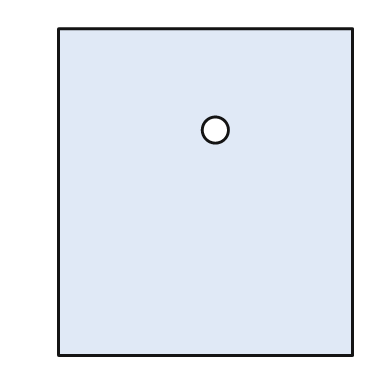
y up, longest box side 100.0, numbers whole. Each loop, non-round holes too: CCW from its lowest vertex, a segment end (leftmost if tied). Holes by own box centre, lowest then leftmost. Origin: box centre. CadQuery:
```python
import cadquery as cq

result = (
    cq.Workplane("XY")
    .moveTo(-45.0, -50.0)
    .lineTo(45.0, -50.0)
    .lineTo(45.0, 50.0)
    .lineTo(-45.0, 50.0)
    .close()
    .moveTo(3.0, 19.0)
    .circle(4.0)
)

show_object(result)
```